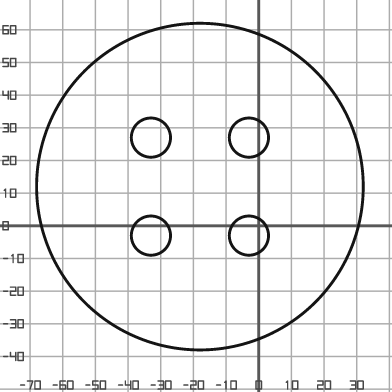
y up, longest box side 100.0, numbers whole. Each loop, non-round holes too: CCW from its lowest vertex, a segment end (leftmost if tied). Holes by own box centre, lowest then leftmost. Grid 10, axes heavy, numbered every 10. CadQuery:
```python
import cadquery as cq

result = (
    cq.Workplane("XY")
    .moveTo(-18.0, 12.0)
    .circle(50.0)
    .moveTo(-33.0, -3.0)
    .circle(6.0)
    .moveTo(-3.0, -3.0)
    .circle(6.0)
    .moveTo(-33.0, 27.0)
    .circle(6.0)
    .moveTo(-3.0, 27.0)
    .circle(6.0)
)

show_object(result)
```